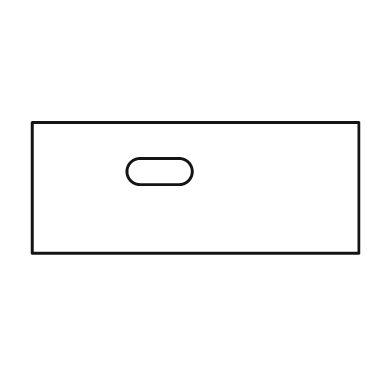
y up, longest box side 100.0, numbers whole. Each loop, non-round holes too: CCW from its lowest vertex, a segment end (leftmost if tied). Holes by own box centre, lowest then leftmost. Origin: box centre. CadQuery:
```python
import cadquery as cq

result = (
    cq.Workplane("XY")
    .moveTo(-50.0, -20.0)
    .lineTo(50.0, -20.0)
    .lineTo(50.0, 20.0)
    .lineTo(-50.0, 20.0)
    .close()
    .moveTo(-17.0, 1.0)
    .lineTo(-5.0, 1.0)
    .threePointArc((-1.0, 5.0), (-5.0, 9.0))
    .lineTo(-17.0, 9.0)
    .threePointArc((-21.0, 5.0), (-17.0, 1.0))
    .close()
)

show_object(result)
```